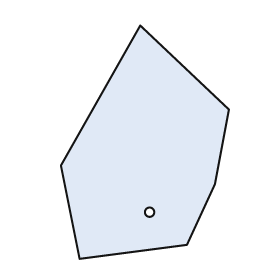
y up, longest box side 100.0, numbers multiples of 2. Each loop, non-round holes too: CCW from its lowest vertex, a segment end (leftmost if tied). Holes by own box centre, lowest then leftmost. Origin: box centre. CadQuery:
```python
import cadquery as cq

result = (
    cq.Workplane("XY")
    .moveTo(-28.0, -50.0)
    .lineTo(18.0, -44.0)
    .lineTo(30.0, -18.0)
    .lineTo(36.0, 14.0)
    .lineTo(-2.0, 50.0)
    .lineTo(-36.0, -10.0)
    .close()
    .moveTo(2.0, -30.0)
    .circle(2.0)
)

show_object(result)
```